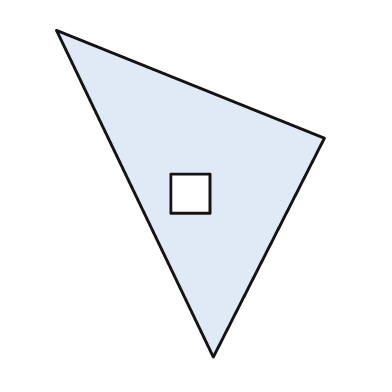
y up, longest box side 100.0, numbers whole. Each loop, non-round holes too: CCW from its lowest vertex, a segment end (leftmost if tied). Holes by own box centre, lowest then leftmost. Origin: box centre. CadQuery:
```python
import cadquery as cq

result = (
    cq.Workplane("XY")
    .moveTo(7.0, -50.0)
    .lineTo(41.0, 17.0)
    .lineTo(-41.0, 50.0)
    .close()
    .moveTo(-6.0, -6.0)
    .lineTo(6.0, -6.0)
    .lineTo(6.0, 6.0)
    .lineTo(-6.0, 6.0)
    .close()
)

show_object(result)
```